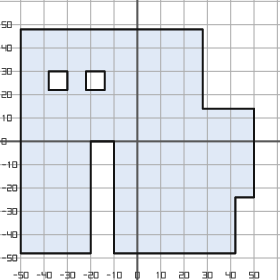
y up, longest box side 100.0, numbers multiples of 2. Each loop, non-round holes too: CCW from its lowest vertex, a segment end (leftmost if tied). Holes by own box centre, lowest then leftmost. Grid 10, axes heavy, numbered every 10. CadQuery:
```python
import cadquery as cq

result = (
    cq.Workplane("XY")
    .moveTo(-50.0, -48.0)
    .lineTo(-20.0, -48.0)
    .lineTo(-20.0, 0.0)
    .lineTo(-10.0, 0.0)
    .lineTo(-10.0, -48.0)
    .lineTo(42.0, -48.0)
    .lineTo(42.0, -24.0)
    .lineTo(50.0, -24.0)
    .lineTo(50.0, 14.0)
    .lineTo(28.0, 14.0)
    .lineTo(28.0, 48.0)
    .lineTo(-50.0, 48.0)
    .close()
    .moveTo(-38.0, 22.0)
    .lineTo(-30.0, 22.0)
    .lineTo(-30.0, 30.0)
    .lineTo(-38.0, 30.0)
    .close()
    .moveTo(-22.0, 22.0)
    .lineTo(-14.0, 22.0)
    .lineTo(-14.0, 30.0)
    .lineTo(-22.0, 30.0)
    .close()
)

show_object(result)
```